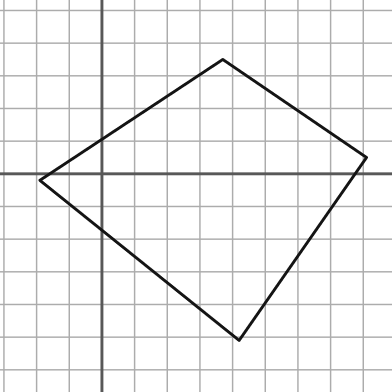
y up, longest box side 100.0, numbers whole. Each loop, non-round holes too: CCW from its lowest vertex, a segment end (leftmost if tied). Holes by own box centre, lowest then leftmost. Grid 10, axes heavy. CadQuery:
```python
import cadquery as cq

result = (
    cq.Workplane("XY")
    .moveTo(42.0, -51.0)
    .lineTo(81.0, 5.0)
    .lineTo(37.0, 35.0)
    .lineTo(-19.0, -2.0)
    .close()
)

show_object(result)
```